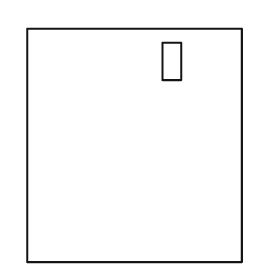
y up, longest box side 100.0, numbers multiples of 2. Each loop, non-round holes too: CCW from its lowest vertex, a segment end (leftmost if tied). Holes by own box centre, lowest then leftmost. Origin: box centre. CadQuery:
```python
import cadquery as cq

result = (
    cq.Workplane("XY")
    .moveTo(-46.0, -50.0)
    .lineTo(46.0, -50.0)
    .lineTo(46.0, 50.0)
    .lineTo(-46.0, 50.0)
    .close()
    .moveTo(12.0, 28.0)
    .lineTo(20.0, 28.0)
    .lineTo(20.0, 44.0)
    .lineTo(12.0, 44.0)
    .close()
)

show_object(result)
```